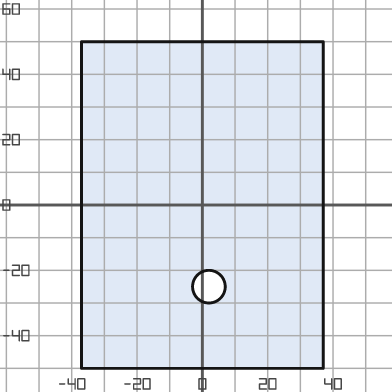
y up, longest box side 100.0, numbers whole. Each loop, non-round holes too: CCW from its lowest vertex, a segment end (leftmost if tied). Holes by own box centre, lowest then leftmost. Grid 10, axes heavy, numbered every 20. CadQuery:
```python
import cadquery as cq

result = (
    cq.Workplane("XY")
    .moveTo(-37.0, -50.0)
    .lineTo(37.0, -50.0)
    .lineTo(37.0, 50.0)
    .lineTo(-37.0, 50.0)
    .close()
    .moveTo(2.0, -25.0)
    .circle(5.0)
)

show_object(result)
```